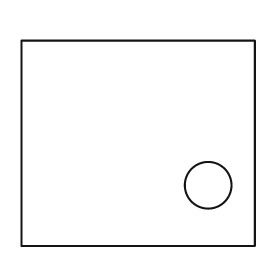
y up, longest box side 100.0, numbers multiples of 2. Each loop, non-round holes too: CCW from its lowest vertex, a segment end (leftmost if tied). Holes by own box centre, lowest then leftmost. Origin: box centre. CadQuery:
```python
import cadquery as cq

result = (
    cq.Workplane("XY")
    .moveTo(-50.0, -44.0)
    .lineTo(50.0, -44.0)
    .lineTo(50.0, 44.0)
    .lineTo(-50.0, 44.0)
    .close()
    .moveTo(30.0, -18.0)
    .circle(10.0)
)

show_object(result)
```